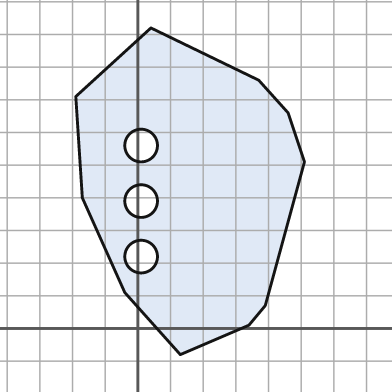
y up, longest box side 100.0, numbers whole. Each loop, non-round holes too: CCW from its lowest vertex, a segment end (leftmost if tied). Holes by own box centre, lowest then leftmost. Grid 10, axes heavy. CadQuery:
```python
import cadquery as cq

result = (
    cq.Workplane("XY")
    .moveTo(13.0, -8.0)
    .lineTo(34.0, 1.0)
    .lineTo(39.0, 7.0)
    .lineTo(51.0, 51.0)
    .lineTo(46.0, 66.0)
    .lineTo(37.0, 76.0)
    .lineTo(4.0, 92.0)
    .lineTo(-19.0, 71.0)
    .lineTo(-17.0, 40.0)
    .lineTo(-4.0, 11.0)
    .close()
    .moveTo(1.0, 22.0)
    .circle(5.0)
    .moveTo(1.0, 39.0)
    .circle(5.0)
    .moveTo(1.0, 56.0)
    .circle(5.0)
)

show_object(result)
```